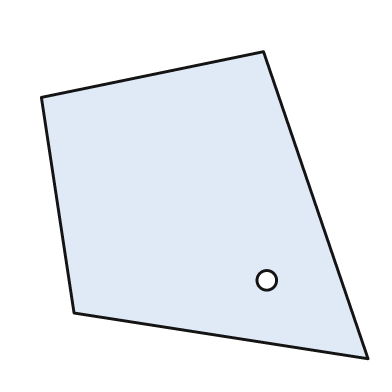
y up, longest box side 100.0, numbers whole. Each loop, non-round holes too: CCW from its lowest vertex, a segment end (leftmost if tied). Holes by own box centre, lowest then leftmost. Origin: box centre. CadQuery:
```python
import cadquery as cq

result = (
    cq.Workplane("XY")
    .moveTo(50.0, -47.0)
    .lineTo(18.0, 47.0)
    .lineTo(-50.0, 33.0)
    .lineTo(-40.0, -33.0)
    .close()
    .moveTo(19.0, -23.0)
    .circle(3.0)
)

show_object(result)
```